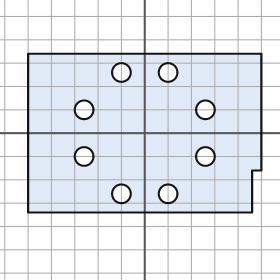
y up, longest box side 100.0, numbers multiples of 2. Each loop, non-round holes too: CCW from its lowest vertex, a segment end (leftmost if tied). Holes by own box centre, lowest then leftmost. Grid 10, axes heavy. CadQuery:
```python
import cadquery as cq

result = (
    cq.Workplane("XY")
    .moveTo(-50.0, -34.0)
    .lineTo(46.0, -34.0)
    .lineTo(46.0, -16.0)
    .lineTo(50.0, -16.0)
    .lineTo(50.0, 34.0)
    .lineTo(-50.0, 34.0)
    .close()
    .moveTo(-10.0, -26.0)
    .circle(4.0)
    .moveTo(10.0, -26.0)
    .circle(4.0)
    .moveTo(-26.0, -10.0)
    .circle(4.0)
    .moveTo(26.0, -10.0)
    .circle(4.0)
    .moveTo(-26.0, 10.0)
    .circle(4.0)
    .moveTo(26.0, 10.0)
    .circle(4.0)
    .moveTo(-10.0, 26.0)
    .circle(4.0)
    .moveTo(10.0, 26.0)
    .circle(4.0)
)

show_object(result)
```